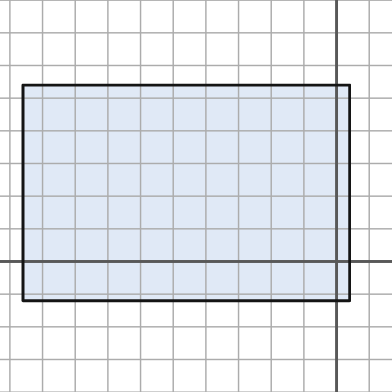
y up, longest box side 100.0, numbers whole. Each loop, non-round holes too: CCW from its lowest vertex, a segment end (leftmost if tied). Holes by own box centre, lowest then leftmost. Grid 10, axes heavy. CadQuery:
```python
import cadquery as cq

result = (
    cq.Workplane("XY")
    .moveTo(-96.0, -12.0)
    .lineTo(4.0, -12.0)
    .lineTo(4.0, 54.0)
    .lineTo(-96.0, 54.0)
    .close()
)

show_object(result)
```